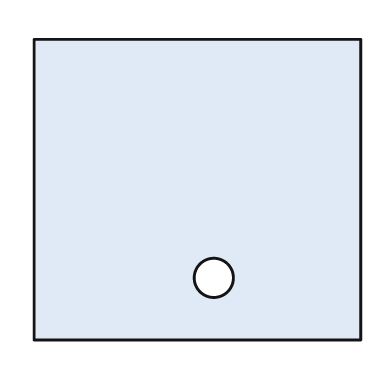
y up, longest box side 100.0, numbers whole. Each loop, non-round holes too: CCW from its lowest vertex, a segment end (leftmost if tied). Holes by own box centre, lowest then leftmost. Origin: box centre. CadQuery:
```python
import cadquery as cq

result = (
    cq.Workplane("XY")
    .moveTo(-50.0, -46.0)
    .lineTo(50.0, -46.0)
    .lineTo(50.0, 46.0)
    .lineTo(-50.0, 46.0)
    .close()
    .moveTo(5.0, -27.0)
    .circle(6.0)
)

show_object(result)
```